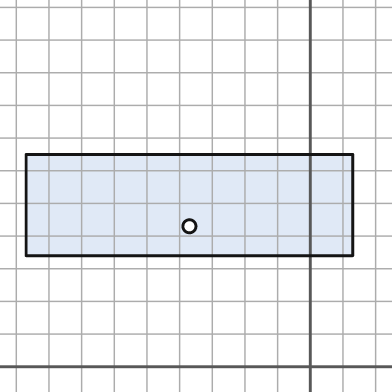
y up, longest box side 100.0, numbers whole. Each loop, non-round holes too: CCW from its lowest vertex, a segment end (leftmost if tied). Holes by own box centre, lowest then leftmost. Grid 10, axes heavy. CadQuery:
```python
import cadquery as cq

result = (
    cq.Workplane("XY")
    .moveTo(-87.0, 34.0)
    .lineTo(13.0, 34.0)
    .lineTo(13.0, 65.0)
    .lineTo(-87.0, 65.0)
    .close()
    .moveTo(-37.0, 43.0)
    .circle(2.0)
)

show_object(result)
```